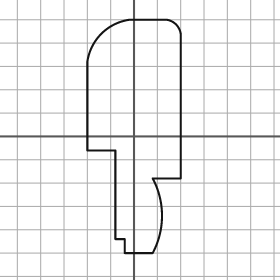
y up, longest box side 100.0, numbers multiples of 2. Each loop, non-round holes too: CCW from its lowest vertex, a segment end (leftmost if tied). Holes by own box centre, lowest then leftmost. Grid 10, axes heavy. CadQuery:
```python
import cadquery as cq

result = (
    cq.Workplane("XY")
    .moveTo(-4.0, -50.0)
    .lineTo(8.0, -50.0)
    .threePointArc((12.0, -34.0), (8.0, -18.0))
    .lineTo(20.0, -18.0)
    .lineTo(20.0, 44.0)
    .threePointArc((18.0, 48.0), (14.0, 50.0))
    .lineTo(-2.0, 50.0)
    .threePointArc((-14.0, 44.0), (-20.0, 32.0))
    .lineTo(-20.0, -6.0)
    .lineTo(-8.0, -6.0)
    .lineTo(-8.0, -44.0)
    .lineTo(-4.0, -44.0)
    .close()
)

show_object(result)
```